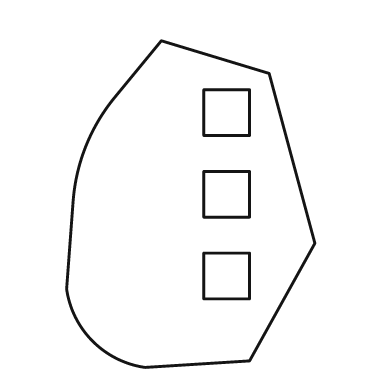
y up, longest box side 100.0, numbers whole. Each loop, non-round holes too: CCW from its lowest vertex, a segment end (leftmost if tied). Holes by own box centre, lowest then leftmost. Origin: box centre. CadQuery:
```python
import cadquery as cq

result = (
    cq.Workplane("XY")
    .moveTo(-14.0, -50.0)
    .lineTo(18.0, -48.0)
    .lineTo(38.0, -12.0)
    .lineTo(24.0, 40.0)
    .lineTo(-9.0, 50.0)
    .lineTo(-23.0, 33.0)
    .threePointArc((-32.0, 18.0), (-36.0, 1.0))
    .lineTo(-38.0, -26.0)
    .threePointArc((-30.0, -42.0), (-14.0, -50.0))
    .close()
    .moveTo(4.0, -29.0)
    .lineTo(18.0, -29.0)
    .lineTo(18.0, -15.0)
    .lineTo(4.0, -15.0)
    .close()
    .moveTo(4.0, -4.0)
    .lineTo(18.0, -4.0)
    .lineTo(18.0, 10.0)
    .lineTo(4.0, 10.0)
    .close()
    .moveTo(4.0, 21.0)
    .lineTo(18.0, 21.0)
    .lineTo(18.0, 35.0)
    .lineTo(4.0, 35.0)
    .close()
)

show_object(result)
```